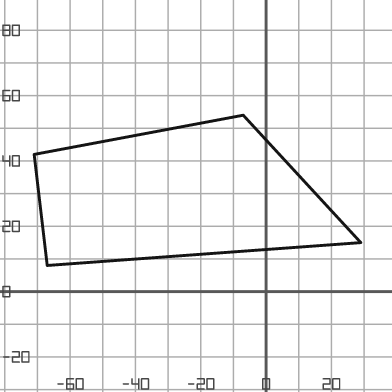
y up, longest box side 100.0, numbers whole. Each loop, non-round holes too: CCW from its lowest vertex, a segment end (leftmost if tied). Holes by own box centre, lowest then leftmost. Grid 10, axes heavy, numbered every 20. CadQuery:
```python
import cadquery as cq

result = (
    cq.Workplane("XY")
    .moveTo(-67.0, 8.0)
    .lineTo(29.0, 15.0)
    .lineTo(-7.0, 54.0)
    .lineTo(-71.0, 42.0)
    .close()
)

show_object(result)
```